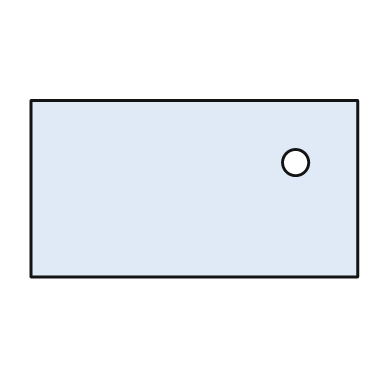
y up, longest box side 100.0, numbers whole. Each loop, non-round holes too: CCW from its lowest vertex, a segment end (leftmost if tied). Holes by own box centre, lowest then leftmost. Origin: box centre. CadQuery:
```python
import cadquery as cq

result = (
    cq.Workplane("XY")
    .moveTo(-50.0, -27.0)
    .lineTo(50.0, -27.0)
    .lineTo(50.0, 27.0)
    .lineTo(-50.0, 27.0)
    .close()
    .moveTo(31.0, 8.0)
    .circle(4.0)
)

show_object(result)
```